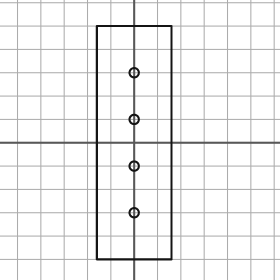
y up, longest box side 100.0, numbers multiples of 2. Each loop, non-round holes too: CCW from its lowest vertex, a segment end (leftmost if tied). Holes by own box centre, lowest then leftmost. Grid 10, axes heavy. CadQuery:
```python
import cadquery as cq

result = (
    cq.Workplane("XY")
    .moveTo(-16.0, -50.0)
    .lineTo(16.0, -50.0)
    .lineTo(16.0, 50.0)
    .lineTo(-16.0, 50.0)
    .close()
    .moveTo(0.0, -30.0)
    .circle(2.0)
    .moveTo(0.0, -10.0)
    .circle(2.0)
    .moveTo(0.0, 10.0)
    .circle(2.0)
    .moveTo(0.0, 30.0)
    .circle(2.0)
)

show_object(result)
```